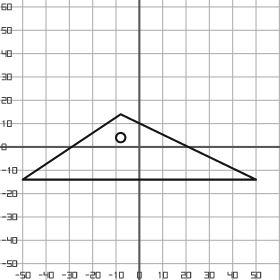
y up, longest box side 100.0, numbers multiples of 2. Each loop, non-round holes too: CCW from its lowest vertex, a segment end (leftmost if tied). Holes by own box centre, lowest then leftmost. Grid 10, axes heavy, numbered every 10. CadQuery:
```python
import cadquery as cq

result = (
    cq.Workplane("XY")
    .moveTo(-50.0, -14.0)
    .lineTo(50.0, -14.0)
    .lineTo(-8.0, 14.0)
    .close()
    .moveTo(-8.0, 4.0)
    .circle(2.0)
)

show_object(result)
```